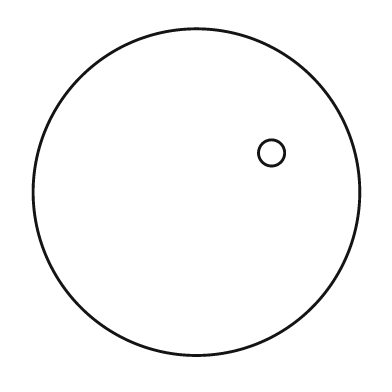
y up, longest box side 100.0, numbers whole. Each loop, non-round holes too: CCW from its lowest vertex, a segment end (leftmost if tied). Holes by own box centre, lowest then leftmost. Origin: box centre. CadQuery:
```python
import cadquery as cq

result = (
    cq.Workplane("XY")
    .moveTo(0.0, 0.0)
    .circle(50.0)
    .moveTo(23.0, 12.0)
    .circle(4.0)
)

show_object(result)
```